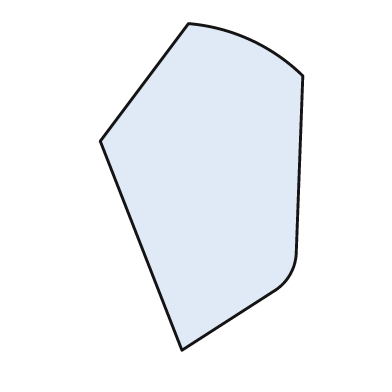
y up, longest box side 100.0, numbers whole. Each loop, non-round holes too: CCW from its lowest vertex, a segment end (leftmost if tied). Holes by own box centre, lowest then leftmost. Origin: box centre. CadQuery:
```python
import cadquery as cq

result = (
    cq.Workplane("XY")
    .moveTo(-6.0, -50.0)
    .lineTo(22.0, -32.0)
    .threePointArc((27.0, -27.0), (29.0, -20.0))
    .lineTo(31.0, 34.0)
    .threePointArc((15.0, 45.0), (-4.0, 50.0))
    .lineTo(-31.0, 14.0)
    .close()
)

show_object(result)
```